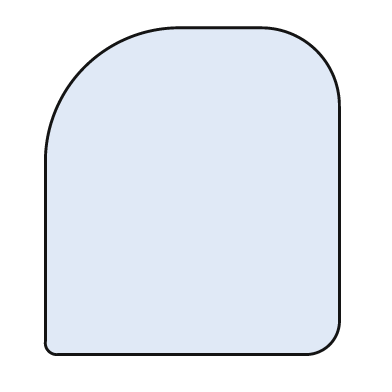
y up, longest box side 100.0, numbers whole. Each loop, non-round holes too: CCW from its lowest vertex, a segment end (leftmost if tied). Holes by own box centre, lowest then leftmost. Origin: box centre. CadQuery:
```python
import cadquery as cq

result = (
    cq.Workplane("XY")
    .moveTo(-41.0, -50.0)
    .lineTo(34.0, -50.0)
    .threePointArc((42.0, -47.0), (45.0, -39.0))
    .lineTo(45.0, 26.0)
    .threePointArc((38.0, 43.0), (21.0, 50.0))
    .lineTo(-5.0, 50.0)
    .threePointArc((-33.0, 38.0), (-45.0, 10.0))
    .lineTo(-45.0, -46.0)
    .threePointArc((-44.0, -49.0), (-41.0, -50.0))
    .close()
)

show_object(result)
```